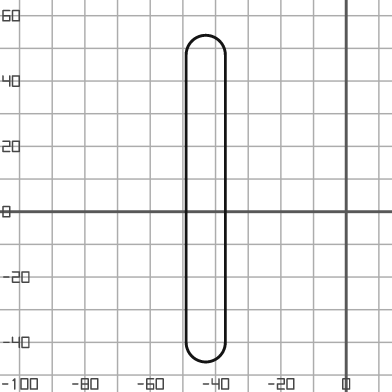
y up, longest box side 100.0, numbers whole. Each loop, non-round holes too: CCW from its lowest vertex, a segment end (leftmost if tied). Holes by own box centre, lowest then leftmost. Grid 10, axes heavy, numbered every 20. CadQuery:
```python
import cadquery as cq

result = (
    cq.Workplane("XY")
    .moveTo(-49.0, -40.0)
    .threePointArc((-43.0, -46.0), (-37.0, -40.0))
    .lineTo(-37.0, 48.0)
    .threePointArc((-43.0, 54.0), (-49.0, 48.0))
    .close()
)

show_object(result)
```